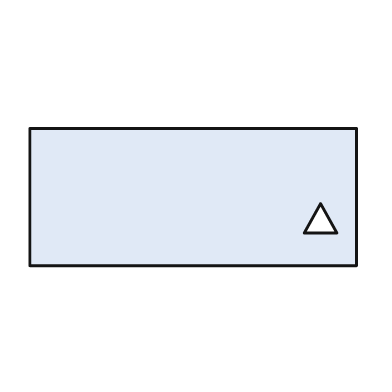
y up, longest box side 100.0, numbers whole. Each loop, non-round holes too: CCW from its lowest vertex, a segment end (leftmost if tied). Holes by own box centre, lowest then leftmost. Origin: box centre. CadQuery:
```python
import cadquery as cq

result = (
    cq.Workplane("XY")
    .moveTo(-50.0, -21.0)
    .lineTo(50.0, -21.0)
    .lineTo(50.0, 21.0)
    .lineTo(-50.0, 21.0)
    .close()
    .moveTo(34.0, -11.0)
    .lineTo(44.0, -11.0)
    .lineTo(39.0, -2.0)
    .close()
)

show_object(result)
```